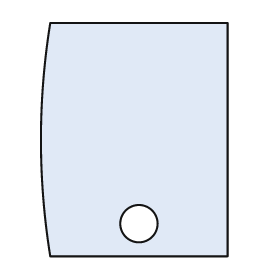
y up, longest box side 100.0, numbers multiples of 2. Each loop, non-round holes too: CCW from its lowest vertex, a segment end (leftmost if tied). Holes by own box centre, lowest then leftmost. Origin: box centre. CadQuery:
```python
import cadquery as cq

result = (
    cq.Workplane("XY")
    .moveTo(-36.0, -50.0)
    .lineTo(40.0, -50.0)
    .lineTo(40.0, 50.0)
    .lineTo(-36.0, 50.0)
    .threePointArc((-40.0, 0.0), (-36.0, -50.0))
    .close()
    .moveTo(2.0, -36.0)
    .circle(8.0)
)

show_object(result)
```